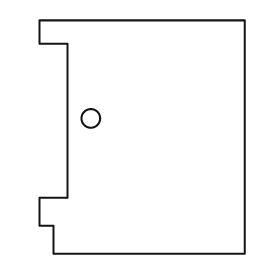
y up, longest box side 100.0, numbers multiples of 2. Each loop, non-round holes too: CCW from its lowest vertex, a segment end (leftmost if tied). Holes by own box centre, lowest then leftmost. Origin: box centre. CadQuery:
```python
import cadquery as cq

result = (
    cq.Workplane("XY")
    .moveTo(-38.0, -50.0)
    .lineTo(44.0, -50.0)
    .lineTo(44.0, 50.0)
    .lineTo(-44.0, 50.0)
    .lineTo(-44.0, 40.0)
    .lineTo(-32.0, 40.0)
    .lineTo(-32.0, -26.0)
    .lineTo(-44.0, -26.0)
    .lineTo(-44.0, -38.0)
    .lineTo(-38.0, -38.0)
    .close()
    .moveTo(-22.0, 8.0)
    .circle(4.0)
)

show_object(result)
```